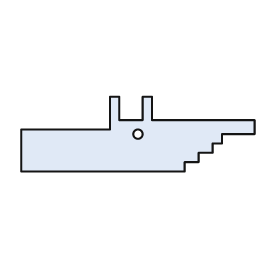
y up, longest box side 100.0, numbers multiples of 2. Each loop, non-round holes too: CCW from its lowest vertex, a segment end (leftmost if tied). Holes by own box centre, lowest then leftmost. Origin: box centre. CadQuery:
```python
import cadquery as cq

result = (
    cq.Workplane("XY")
    .moveTo(-50.0, -16.0)
    .lineTo(20.0, -16.0)
    .lineTo(20.0, -12.0)
    .lineTo(26.0, -12.0)
    .lineTo(26.0, -8.0)
    .lineTo(32.0, -8.0)
    .lineTo(32.0, -4.0)
    .lineTo(36.0, -4.0)
    .lineTo(36.0, 0.0)
    .lineTo(50.0, 0.0)
    .lineTo(50.0, 6.0)
    .lineTo(6.0, 6.0)
    .lineTo(6.0, 16.0)
    .lineTo(2.0, 16.0)
    .lineTo(2.0, 6.0)
    .lineTo(-8.0, 6.0)
    .lineTo(-8.0, 16.0)
    .lineTo(-12.0, 16.0)
    .lineTo(-12.0, 2.0)
    .lineTo(-50.0, 2.0)
    .close()
    .moveTo(0.0, 0.0)
    .circle(2.0)
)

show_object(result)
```